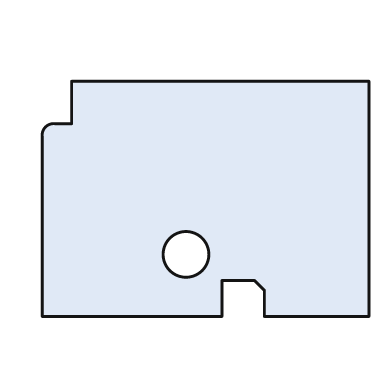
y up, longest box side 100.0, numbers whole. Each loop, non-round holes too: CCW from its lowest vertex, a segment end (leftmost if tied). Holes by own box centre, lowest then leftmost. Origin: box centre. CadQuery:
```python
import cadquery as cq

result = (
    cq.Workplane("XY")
    .moveTo(-50.0, -36.0)
    .lineTo(5.0, -36.0)
    .lineTo(5.0, -25.0)
    .lineTo(15.0, -25.0)
    .lineTo(18.0, -28.0)
    .lineTo(18.0, -36.0)
    .lineTo(50.0, -36.0)
    .lineTo(50.0, 36.0)
    .lineTo(-41.0, 36.0)
    .lineTo(-41.0, 23.0)
    .lineTo(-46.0, 23.0)
    .threePointArc((-49.0, 22.0), (-50.0, 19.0))
    .close()
    .moveTo(-6.0, -17.0)
    .circle(7.0)
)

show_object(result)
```